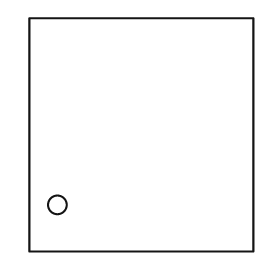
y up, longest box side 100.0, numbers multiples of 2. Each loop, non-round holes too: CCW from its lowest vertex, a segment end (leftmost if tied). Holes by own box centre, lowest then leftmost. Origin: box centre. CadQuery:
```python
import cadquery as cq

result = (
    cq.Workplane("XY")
    .moveTo(-48.0, -50.0)
    .lineTo(48.0, -50.0)
    .lineTo(48.0, 50.0)
    .lineTo(-48.0, 50.0)
    .close()
    .moveTo(-36.0, -30.0)
    .circle(4.0)
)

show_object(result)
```